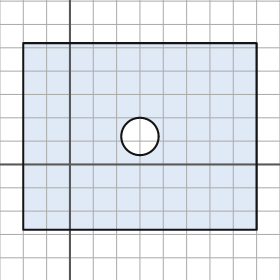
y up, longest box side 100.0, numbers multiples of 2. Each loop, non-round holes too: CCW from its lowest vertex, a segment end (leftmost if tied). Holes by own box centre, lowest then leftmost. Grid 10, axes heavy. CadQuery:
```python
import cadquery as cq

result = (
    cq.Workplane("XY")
    .moveTo(-20.0, -28.0)
    .lineTo(80.0, -28.0)
    .lineTo(80.0, 52.0)
    .lineTo(-20.0, 52.0)
    .close()
    .moveTo(30.0, 12.0)
    .circle(8.0)
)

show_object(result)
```